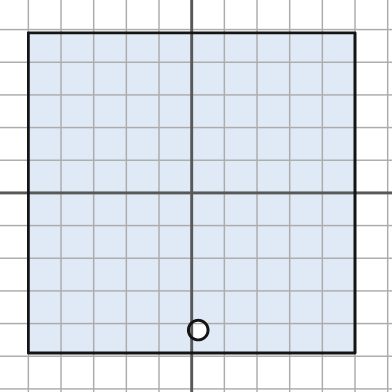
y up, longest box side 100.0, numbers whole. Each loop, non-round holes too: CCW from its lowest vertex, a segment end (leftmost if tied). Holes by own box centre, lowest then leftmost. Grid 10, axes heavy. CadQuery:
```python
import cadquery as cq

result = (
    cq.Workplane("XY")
    .moveTo(-50.0, -49.0)
    .lineTo(50.0, -49.0)
    .lineTo(50.0, 49.0)
    .lineTo(-50.0, 49.0)
    .close()
    .moveTo(2.0, -42.0)
    .circle(3.0)
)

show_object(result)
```